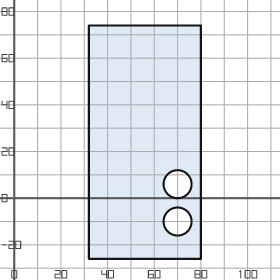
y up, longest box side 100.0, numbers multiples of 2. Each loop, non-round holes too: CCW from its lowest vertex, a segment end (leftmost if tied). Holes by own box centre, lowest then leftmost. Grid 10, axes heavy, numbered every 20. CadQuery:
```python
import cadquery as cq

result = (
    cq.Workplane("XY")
    .moveTo(32.0, -26.0)
    .lineTo(80.0, -26.0)
    .lineTo(80.0, 74.0)
    .lineTo(32.0, 74.0)
    .close()
    .moveTo(70.0, -10.0)
    .circle(6.0)
    .moveTo(70.0, 6.0)
    .circle(6.0)
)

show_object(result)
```